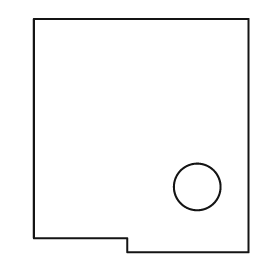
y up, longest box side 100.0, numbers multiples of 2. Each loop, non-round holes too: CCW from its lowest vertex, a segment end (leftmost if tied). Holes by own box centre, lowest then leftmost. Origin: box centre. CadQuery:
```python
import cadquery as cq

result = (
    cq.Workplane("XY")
    .moveTo(-6.0, -50.0)
    .lineTo(46.0, -50.0)
    .lineTo(46.0, 50.0)
    .lineTo(-46.0, 50.0)
    .lineTo(-46.0, -44.0)
    .lineTo(-6.0, -44.0)
    .close()
    .moveTo(24.0, -22.0)
    .circle(10.0)
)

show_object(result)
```